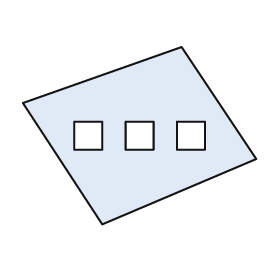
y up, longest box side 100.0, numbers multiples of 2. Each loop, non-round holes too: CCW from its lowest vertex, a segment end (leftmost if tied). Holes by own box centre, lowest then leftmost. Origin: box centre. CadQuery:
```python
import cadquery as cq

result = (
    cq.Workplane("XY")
    .moveTo(-16.0, -38.0)
    .lineTo(50.0, -10.0)
    .lineTo(18.0, 38.0)
    .lineTo(-50.0, 14.0)
    .close()
    .moveTo(-28.0, -6.0)
    .lineTo(-16.0, -6.0)
    .lineTo(-16.0, 6.0)
    .lineTo(-28.0, 6.0)
    .close()
    .moveTo(-6.0, -6.0)
    .lineTo(6.0, -6.0)
    .lineTo(6.0, 6.0)
    .lineTo(-6.0, 6.0)
    .close()
    .moveTo(16.0, -6.0)
    .lineTo(28.0, -6.0)
    .lineTo(28.0, 6.0)
    .lineTo(16.0, 6.0)
    .close()
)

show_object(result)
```